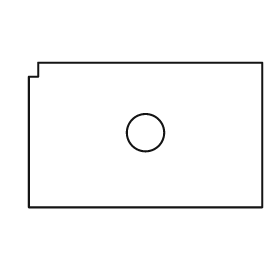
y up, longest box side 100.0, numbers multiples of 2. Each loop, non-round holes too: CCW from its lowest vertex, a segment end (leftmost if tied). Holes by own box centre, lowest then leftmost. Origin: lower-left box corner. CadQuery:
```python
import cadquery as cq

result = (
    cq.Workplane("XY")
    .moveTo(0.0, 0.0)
    .lineTo(100.0, 0.0)
    .lineTo(100.0, 62.0)
    .lineTo(4.0, 62.0)
    .lineTo(4.0, 56.0)
    .lineTo(0.0, 56.0)
    .close()
    .moveTo(50.0, 32.0)
    .circle(8.0)
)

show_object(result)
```